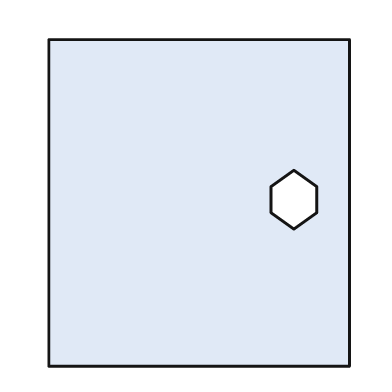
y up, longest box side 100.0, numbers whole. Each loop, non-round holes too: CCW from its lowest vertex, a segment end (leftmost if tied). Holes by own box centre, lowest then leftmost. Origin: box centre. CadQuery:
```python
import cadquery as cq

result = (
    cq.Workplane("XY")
    .moveTo(-46.0, -50.0)
    .lineTo(46.0, -50.0)
    .lineTo(46.0, 50.0)
    .lineTo(-46.0, 50.0)
    .close()
    .moveTo(29.0, -8.0)
    .lineTo(36.0, -3.0)
    .lineTo(36.0, 5.0)
    .lineTo(29.0, 10.0)
    .lineTo(22.0, 5.0)
    .lineTo(22.0, -3.0)
    .close()
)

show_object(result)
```